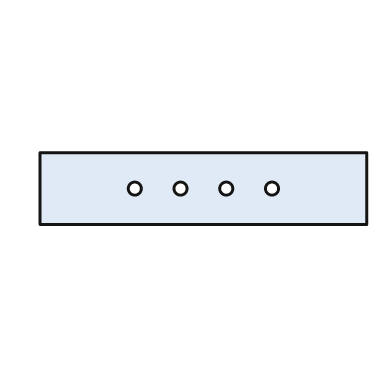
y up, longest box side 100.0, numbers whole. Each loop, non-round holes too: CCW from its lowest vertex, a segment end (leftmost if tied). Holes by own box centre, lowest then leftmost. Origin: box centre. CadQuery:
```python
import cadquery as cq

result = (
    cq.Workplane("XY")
    .moveTo(-50.0, -11.0)
    .lineTo(50.0, -11.0)
    .lineTo(50.0, 11.0)
    .lineTo(-50.0, 11.0)
    .close()
    .moveTo(-21.0, 0.0)
    .circle(2.0)
    .moveTo(-7.0, 0.0)
    .circle(2.0)
    .moveTo(7.0, 0.0)
    .circle(2.0)
    .moveTo(21.0, 0.0)
    .circle(2.0)
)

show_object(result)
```